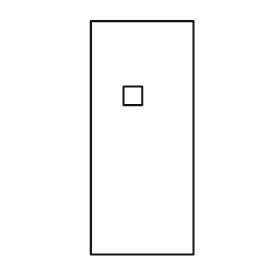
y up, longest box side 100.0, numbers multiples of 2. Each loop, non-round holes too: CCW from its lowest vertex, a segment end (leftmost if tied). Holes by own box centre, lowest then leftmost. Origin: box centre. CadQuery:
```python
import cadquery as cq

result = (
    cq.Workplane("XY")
    .moveTo(-22.0, -50.0)
    .lineTo(22.0, -50.0)
    .lineTo(22.0, 50.0)
    .lineTo(-22.0, 50.0)
    .close()
    .moveTo(-8.0, 14.0)
    .lineTo(0.0, 14.0)
    .lineTo(0.0, 22.0)
    .lineTo(-8.0, 22.0)
    .close()
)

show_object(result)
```